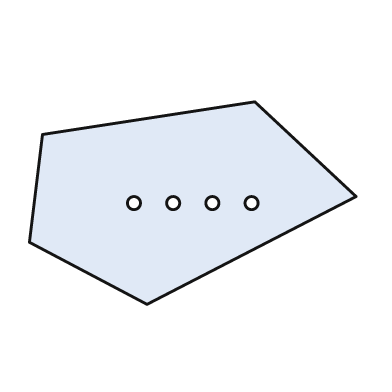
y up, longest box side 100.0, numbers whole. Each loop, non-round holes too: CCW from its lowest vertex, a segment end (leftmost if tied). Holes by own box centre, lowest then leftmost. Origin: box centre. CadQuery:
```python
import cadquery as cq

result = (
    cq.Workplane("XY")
    .moveTo(-14.0, -31.0)
    .lineTo(50.0, 2.0)
    .lineTo(19.0, 31.0)
    .lineTo(-46.0, 21.0)
    .lineTo(-50.0, -12.0)
    .close()
    .moveTo(-18.0, 0.0)
    .circle(2.0)
    .moveTo(-6.0, 0.0)
    .circle(2.0)
    .moveTo(6.0, 0.0)
    .circle(2.0)
    .moveTo(18.0, 0.0)
    .circle(2.0)
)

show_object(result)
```